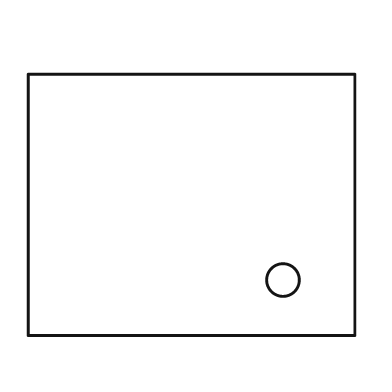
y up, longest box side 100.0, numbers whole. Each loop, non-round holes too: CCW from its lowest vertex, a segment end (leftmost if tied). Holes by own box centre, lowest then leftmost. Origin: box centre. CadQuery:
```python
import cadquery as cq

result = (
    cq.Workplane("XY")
    .moveTo(-50.0, -40.0)
    .lineTo(50.0, -40.0)
    .lineTo(50.0, 40.0)
    .lineTo(-50.0, 40.0)
    .close()
    .moveTo(28.0, -23.0)
    .circle(5.0)
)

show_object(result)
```